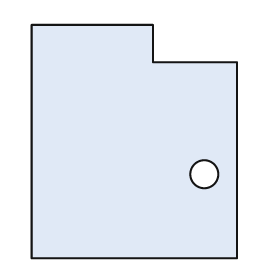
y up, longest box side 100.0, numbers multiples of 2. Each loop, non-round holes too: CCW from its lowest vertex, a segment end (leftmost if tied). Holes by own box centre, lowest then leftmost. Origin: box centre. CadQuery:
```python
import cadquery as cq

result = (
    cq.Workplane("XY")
    .moveTo(-44.0, -50.0)
    .lineTo(44.0, -50.0)
    .lineTo(44.0, 34.0)
    .lineTo(8.0, 34.0)
    .lineTo(8.0, 50.0)
    .lineTo(-44.0, 50.0)
    .close()
    .moveTo(30.0, -14.0)
    .circle(6.0)
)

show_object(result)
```